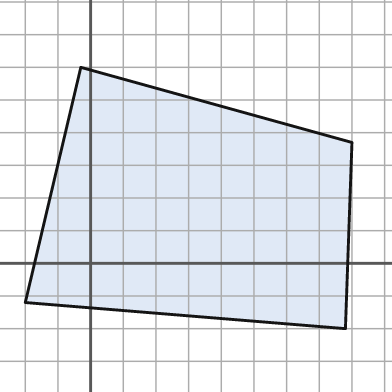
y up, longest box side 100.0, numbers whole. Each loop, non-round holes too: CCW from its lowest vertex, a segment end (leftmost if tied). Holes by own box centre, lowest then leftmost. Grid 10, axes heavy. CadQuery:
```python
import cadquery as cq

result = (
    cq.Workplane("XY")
    .moveTo(78.0, -20.0)
    .lineTo(80.0, 37.0)
    .lineTo(-3.0, 60.0)
    .lineTo(-20.0, -12.0)
    .close()
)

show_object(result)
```